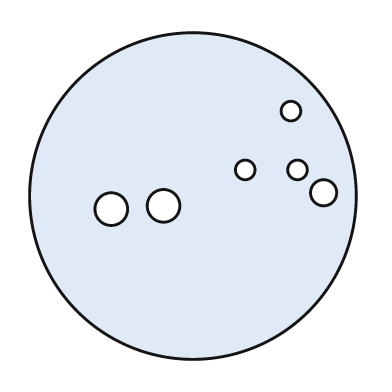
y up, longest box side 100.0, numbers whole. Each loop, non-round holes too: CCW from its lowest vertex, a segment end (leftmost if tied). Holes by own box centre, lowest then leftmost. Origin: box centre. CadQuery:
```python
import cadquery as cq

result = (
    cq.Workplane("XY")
    .moveTo(0.0, 0.0)
    .circle(50.0)
    .moveTo(-25.0, -4.0)
    .circle(5.0)
    .moveTo(-9.0, -3.0)
    .circle(5.0)
    .moveTo(40.0, 1.0)
    .circle(4.0)
    .moveTo(16.0, 8.0)
    .circle(3.0)
    .moveTo(32.0, 8.0)
    .circle(3.0)
    .moveTo(30.0, 26.0)
    .circle(3.0)
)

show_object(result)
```